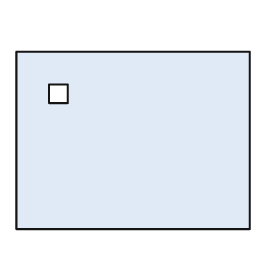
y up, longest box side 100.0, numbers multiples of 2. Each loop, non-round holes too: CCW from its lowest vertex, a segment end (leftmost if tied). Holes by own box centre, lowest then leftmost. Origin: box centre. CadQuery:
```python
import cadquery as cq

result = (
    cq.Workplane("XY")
    .moveTo(-50.0, -38.0)
    .lineTo(50.0, -38.0)
    .lineTo(50.0, 38.0)
    .lineTo(-50.0, 38.0)
    .close()
    .moveTo(-36.0, 16.0)
    .lineTo(-28.0, 16.0)
    .lineTo(-28.0, 24.0)
    .lineTo(-36.0, 24.0)
    .close()
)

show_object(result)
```